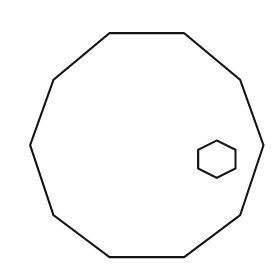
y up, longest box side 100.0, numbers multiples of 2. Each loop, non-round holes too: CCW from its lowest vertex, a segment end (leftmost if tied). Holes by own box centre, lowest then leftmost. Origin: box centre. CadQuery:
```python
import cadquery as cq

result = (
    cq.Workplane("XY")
    .moveTo(-16.0, -48.0)
    .lineTo(16.0, -48.0)
    .lineTo(40.0, -30.0)
    .lineTo(50.0, 0.0)
    .lineTo(40.0, 28.0)
    .lineTo(16.0, 48.0)
    .lineTo(-16.0, 48.0)
    .lineTo(-40.0, 28.0)
    .lineTo(-50.0, 0.0)
    .lineTo(-40.0, -30.0)
    .close()
    .moveTo(30.0, -14.0)
    .lineTo(38.0, -10.0)
    .lineTo(38.0, -2.0)
    .lineTo(30.0, 2.0)
    .lineTo(22.0, -2.0)
    .lineTo(22.0, -10.0)
    .close()
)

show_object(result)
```